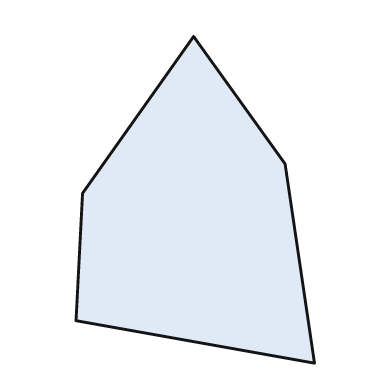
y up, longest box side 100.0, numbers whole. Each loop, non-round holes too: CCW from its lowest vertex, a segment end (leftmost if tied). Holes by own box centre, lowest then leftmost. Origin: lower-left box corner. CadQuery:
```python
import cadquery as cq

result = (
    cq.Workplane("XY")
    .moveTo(73.0, 0.0)
    .lineTo(64.0, 61.0)
    .lineTo(36.0, 100.0)
    .lineTo(2.0, 52.0)
    .lineTo(0.0, 13.0)
    .close()
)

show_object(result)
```